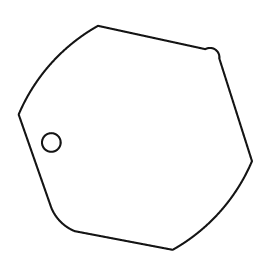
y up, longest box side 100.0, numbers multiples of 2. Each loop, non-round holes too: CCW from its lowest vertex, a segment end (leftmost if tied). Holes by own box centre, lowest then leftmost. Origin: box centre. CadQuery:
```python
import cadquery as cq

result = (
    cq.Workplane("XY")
    .moveTo(16.0, -48.0)
    .threePointArc((36.0, -32.0), (50.0, -10.0))
    .lineTo(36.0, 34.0)
    .threePointArc((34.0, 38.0), (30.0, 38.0))
    .lineTo(-16.0, 48.0)
    .threePointArc((-36.0, 32.0), (-50.0, 10.0))
    .lineTo(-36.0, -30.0)
    .threePointArc((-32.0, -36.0), (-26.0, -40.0))
    .close()
    .moveTo(-36.0, -2.0)
    .circle(4.0)
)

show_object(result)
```